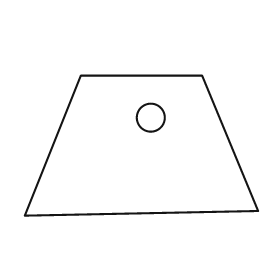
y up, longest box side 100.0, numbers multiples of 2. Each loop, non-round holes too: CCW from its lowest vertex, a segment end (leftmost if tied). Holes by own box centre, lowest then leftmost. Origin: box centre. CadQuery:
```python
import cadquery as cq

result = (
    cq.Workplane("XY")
    .moveTo(-50.0, -30.0)
    .lineTo(50.0, -28.0)
    .lineTo(26.0, 30.0)
    .lineTo(-26.0, 30.0)
    .close()
    .moveTo(4.0, 12.0)
    .circle(6.0)
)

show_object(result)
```